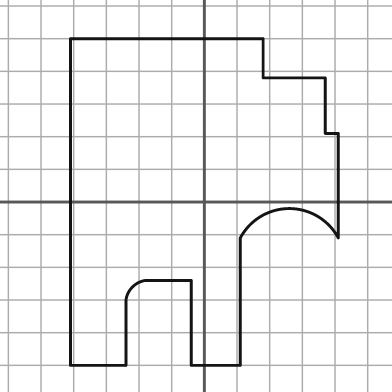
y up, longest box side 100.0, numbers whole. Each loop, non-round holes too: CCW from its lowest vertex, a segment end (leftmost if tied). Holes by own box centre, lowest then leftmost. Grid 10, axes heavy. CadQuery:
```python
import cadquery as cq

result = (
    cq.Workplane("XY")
    .moveTo(-41.0, -50.0)
    .lineTo(-24.0, -50.0)
    .lineTo(-24.0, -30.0)
    .threePointArc((-22.0, -26.0), (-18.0, -24.0))
    .lineTo(-4.0, -24.0)
    .lineTo(-4.0, -50.0)
    .lineTo(11.0, -50.0)
    .lineTo(11.0, -11.0)
    .threePointArc((26.0, -2.0), (41.0, -11.0))
    .lineTo(41.0, 21.0)
    .lineTo(37.0, 21.0)
    .lineTo(37.0, 38.0)
    .lineTo(18.0, 38.0)
    .lineTo(18.0, 50.0)
    .lineTo(-41.0, 50.0)
    .close()
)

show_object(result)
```